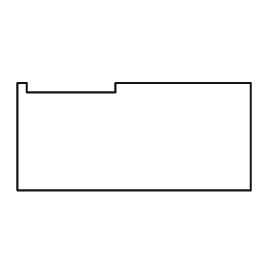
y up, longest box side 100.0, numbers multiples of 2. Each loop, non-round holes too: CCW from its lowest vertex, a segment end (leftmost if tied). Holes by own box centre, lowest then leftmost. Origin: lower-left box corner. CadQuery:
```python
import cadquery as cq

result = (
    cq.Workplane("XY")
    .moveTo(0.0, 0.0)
    .lineTo(100.0, 0.0)
    .lineTo(100.0, 46.0)
    .lineTo(42.0, 46.0)
    .lineTo(42.0, 42.0)
    .lineTo(4.0, 42.0)
    .lineTo(4.0, 46.0)
    .lineTo(0.0, 46.0)
    .close()
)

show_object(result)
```